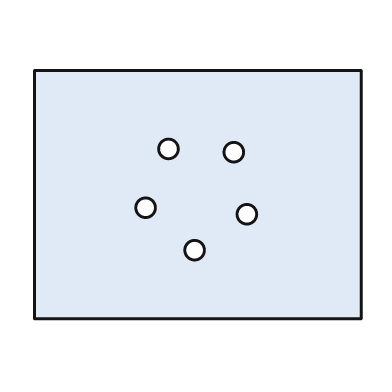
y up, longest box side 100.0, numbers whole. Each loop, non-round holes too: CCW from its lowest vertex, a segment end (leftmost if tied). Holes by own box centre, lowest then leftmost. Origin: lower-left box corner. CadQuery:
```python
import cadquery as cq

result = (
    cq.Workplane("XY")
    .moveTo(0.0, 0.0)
    .lineTo(100.0, 0.0)
    .lineTo(100.0, 76.0)
    .lineTo(0.0, 76.0)
    .close()
    .moveTo(49.0, 21.0)
    .circle(3.0)
    .moveTo(65.0, 32.0)
    .circle(3.0)
    .moveTo(34.0, 34.0)
    .circle(3.0)
    .moveTo(61.0, 51.0)
    .circle(3.0)
    .moveTo(41.0, 52.0)
    .circle(3.0)
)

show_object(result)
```